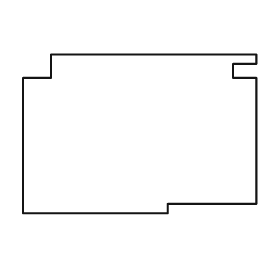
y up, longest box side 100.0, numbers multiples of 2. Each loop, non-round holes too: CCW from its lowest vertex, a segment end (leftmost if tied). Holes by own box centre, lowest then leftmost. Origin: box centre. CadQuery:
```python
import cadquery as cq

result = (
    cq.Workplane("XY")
    .moveTo(-50.0, -34.0)
    .lineTo(12.0, -34.0)
    .lineTo(12.0, -30.0)
    .lineTo(50.0, -30.0)
    .lineTo(50.0, 24.0)
    .lineTo(40.0, 24.0)
    .lineTo(40.0, 30.0)
    .lineTo(50.0, 30.0)
    .lineTo(50.0, 34.0)
    .lineTo(-38.0, 34.0)
    .lineTo(-38.0, 24.0)
    .lineTo(-50.0, 24.0)
    .close()
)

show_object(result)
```